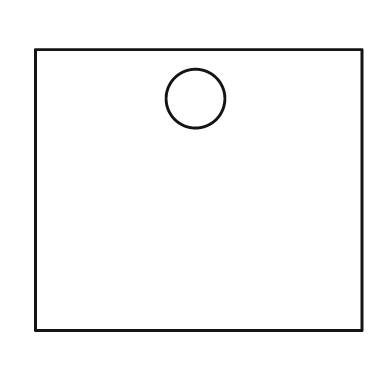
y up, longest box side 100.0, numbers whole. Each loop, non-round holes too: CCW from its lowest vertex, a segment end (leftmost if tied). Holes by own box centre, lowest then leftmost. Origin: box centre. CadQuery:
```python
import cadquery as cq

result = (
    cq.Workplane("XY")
    .moveTo(-50.0, -43.0)
    .lineTo(50.0, -43.0)
    .lineTo(50.0, 43.0)
    .lineTo(-50.0, 43.0)
    .close()
    .moveTo(-1.0, 28.0)
    .circle(9.0)
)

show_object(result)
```